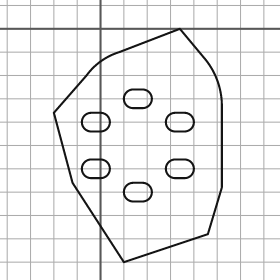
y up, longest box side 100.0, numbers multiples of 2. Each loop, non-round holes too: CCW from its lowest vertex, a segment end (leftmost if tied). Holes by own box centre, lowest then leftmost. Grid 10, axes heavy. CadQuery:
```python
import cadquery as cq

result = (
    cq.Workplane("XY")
    .moveTo(10.0, -100.0)
    .lineTo(46.0, -88.0)
    .lineTo(52.0, -68.0)
    .lineTo(52.0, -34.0)
    .threePointArc((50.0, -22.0), (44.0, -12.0))
    .lineTo(34.0, 0.0)
    .lineTo(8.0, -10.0)
    .threePointArc((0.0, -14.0), (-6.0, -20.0))
    .lineTo(-20.0, -36.0)
    .lineTo(-12.0, -66.0)
    .close()
    .moveTo(14.0, -74.0)
    .lineTo(18.0, -74.0)
    .threePointArc((22.0, -70.0), (18.0, -66.0))
    .lineTo(14.0, -66.0)
    .threePointArc((10.0, -70.0), (14.0, -74.0))
    .close()
    .moveTo(-4.0, -64.0)
    .lineTo(0.0, -64.0)
    .threePointArc((4.0, -60.0), (0.0, -56.0))
    .lineTo(-4.0, -56.0)
    .threePointArc((-8.0, -60.0), (-4.0, -64.0))
    .close()
    .moveTo(32.0, -64.0)
    .lineTo(36.0, -64.0)
    .threePointArc((40.0, -60.0), (36.0, -56.0))
    .lineTo(32.0, -56.0)
    .threePointArc((28.0, -60.0), (32.0, -64.0))
    .close()
    .moveTo(-4.0, -44.0)
    .lineTo(0.0, -44.0)
    .threePointArc((4.0, -40.0), (0.0, -36.0))
    .lineTo(-4.0, -36.0)
    .threePointArc((-8.0, -40.0), (-4.0, -44.0))
    .close()
    .moveTo(32.0, -44.0)
    .lineTo(36.0, -44.0)
    .threePointArc((40.0, -40.0), (36.0, -36.0))
    .lineTo(32.0, -36.0)
    .threePointArc((28.0, -40.0), (32.0, -44.0))
    .close()
    .moveTo(14.0, -34.0)
    .lineTo(18.0, -34.0)
    .threePointArc((22.0, -30.0), (18.0, -26.0))
    .lineTo(14.0, -26.0)
    .threePointArc((10.0, -30.0), (14.0, -34.0))
    .close()
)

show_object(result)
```